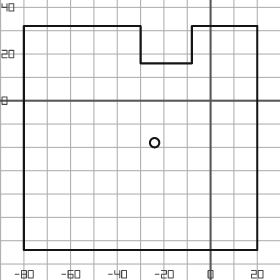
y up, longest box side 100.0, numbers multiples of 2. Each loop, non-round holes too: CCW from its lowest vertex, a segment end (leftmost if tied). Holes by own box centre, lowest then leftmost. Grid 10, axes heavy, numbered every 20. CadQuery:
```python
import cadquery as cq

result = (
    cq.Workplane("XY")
    .moveTo(-80.0, -64.0)
    .lineTo(20.0, -64.0)
    .lineTo(20.0, 32.0)
    .lineTo(-8.0, 32.0)
    .lineTo(-8.0, 16.0)
    .lineTo(-30.0, 16.0)
    .lineTo(-30.0, 32.0)
    .lineTo(-80.0, 32.0)
    .close()
    .moveTo(-24.0, -18.0)
    .circle(2.0)
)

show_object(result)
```